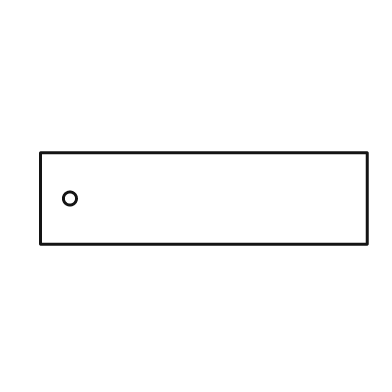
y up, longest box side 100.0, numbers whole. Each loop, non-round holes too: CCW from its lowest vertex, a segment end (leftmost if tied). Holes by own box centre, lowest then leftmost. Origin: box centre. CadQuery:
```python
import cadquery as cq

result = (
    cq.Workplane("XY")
    .moveTo(-50.0, -14.0)
    .lineTo(50.0, -14.0)
    .lineTo(50.0, 14.0)
    .lineTo(-50.0, 14.0)
    .close()
    .moveTo(-41.0, 0.0)
    .circle(2.0)
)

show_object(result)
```